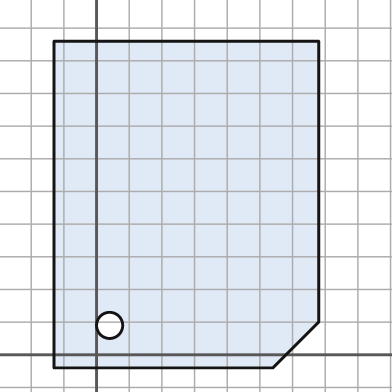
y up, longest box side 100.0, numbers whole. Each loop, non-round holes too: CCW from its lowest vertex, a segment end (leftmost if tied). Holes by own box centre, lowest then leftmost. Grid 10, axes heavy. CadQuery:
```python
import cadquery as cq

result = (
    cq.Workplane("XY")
    .moveTo(-13.0, -4.0)
    .lineTo(54.0, -4.0)
    .lineTo(68.0, 10.0)
    .lineTo(68.0, 96.0)
    .lineTo(-13.0, 96.0)
    .close()
    .moveTo(4.0, 9.0)
    .circle(4.0)
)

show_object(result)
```